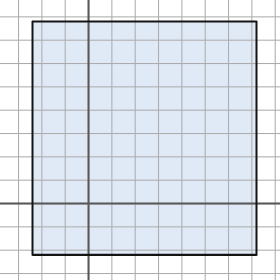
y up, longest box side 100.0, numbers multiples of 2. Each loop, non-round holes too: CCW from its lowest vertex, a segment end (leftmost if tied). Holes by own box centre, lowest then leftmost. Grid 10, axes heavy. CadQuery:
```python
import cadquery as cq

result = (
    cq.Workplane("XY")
    .moveTo(-24.0, -22.0)
    .lineTo(72.0, -22.0)
    .lineTo(72.0, 78.0)
    .lineTo(-24.0, 78.0)
    .close()
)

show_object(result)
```